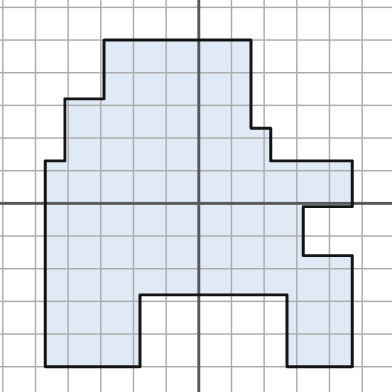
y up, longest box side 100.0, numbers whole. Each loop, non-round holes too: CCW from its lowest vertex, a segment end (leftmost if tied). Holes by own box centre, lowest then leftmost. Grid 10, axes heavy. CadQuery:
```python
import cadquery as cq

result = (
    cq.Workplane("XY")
    .moveTo(-47.0, -50.0)
    .lineTo(-18.0, -50.0)
    .lineTo(-18.0, -28.0)
    .lineTo(27.0, -28.0)
    .lineTo(27.0, -50.0)
    .lineTo(47.0, -50.0)
    .lineTo(47.0, -16.0)
    .lineTo(32.0, -16.0)
    .lineTo(32.0, -1.0)
    .lineTo(47.0, -1.0)
    .lineTo(47.0, 13.0)
    .lineTo(22.0, 13.0)
    .lineTo(22.0, 23.0)
    .lineTo(16.0, 23.0)
    .lineTo(16.0, 50.0)
    .lineTo(-29.0, 50.0)
    .lineTo(-29.0, 32.0)
    .lineTo(-41.0, 32.0)
    .lineTo(-41.0, 13.0)
    .lineTo(-47.0, 13.0)
    .close()
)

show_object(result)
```